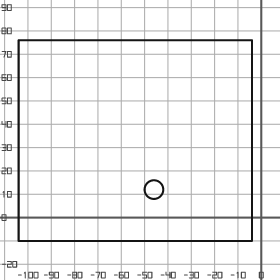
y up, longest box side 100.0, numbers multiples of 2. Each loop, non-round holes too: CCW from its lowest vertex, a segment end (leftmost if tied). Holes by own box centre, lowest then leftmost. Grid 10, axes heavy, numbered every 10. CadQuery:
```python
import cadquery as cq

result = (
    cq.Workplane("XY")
    .moveTo(-104.0, -10.0)
    .lineTo(-4.0, -10.0)
    .lineTo(-4.0, 76.0)
    .lineTo(-104.0, 76.0)
    .close()
    .moveTo(-46.0, 12.0)
    .circle(4.0)
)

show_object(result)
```